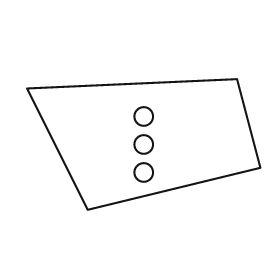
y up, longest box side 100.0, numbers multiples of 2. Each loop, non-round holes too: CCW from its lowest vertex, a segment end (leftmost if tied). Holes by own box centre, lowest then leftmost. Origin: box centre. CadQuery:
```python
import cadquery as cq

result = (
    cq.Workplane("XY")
    .moveTo(-24.0, -28.0)
    .lineTo(50.0, -10.0)
    .lineTo(40.0, 28.0)
    .lineTo(-50.0, 24.0)
    .close()
    .moveTo(0.0, -12.0)
    .circle(4.0)
    .moveTo(0.0, 0.0)
    .circle(4.0)
    .moveTo(0.0, 12.0)
    .circle(4.0)
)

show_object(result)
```